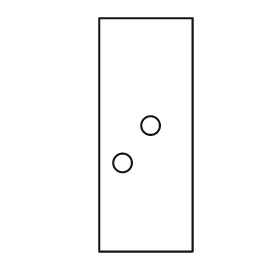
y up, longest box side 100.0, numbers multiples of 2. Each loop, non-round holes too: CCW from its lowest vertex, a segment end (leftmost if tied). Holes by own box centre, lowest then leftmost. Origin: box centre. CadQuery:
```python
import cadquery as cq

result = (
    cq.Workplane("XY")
    .moveTo(-20.0, -50.0)
    .lineTo(20.0, -50.0)
    .lineTo(20.0, 50.0)
    .lineTo(-20.0, 50.0)
    .close()
    .moveTo(-10.0, -12.0)
    .circle(4.0)
    .moveTo(2.0, 4.0)
    .circle(4.0)
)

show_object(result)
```